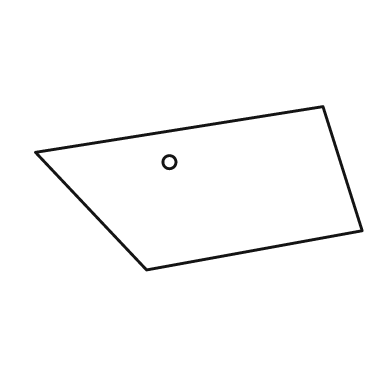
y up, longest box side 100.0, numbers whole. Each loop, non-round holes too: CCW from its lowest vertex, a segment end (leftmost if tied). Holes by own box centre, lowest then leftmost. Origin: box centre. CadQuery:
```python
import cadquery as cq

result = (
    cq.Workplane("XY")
    .moveTo(-16.0, -25.0)
    .lineTo(50.0, -13.0)
    .lineTo(38.0, 25.0)
    .lineTo(-50.0, 11.0)
    .close()
    .moveTo(-9.0, 8.0)
    .circle(2.0)
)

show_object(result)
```